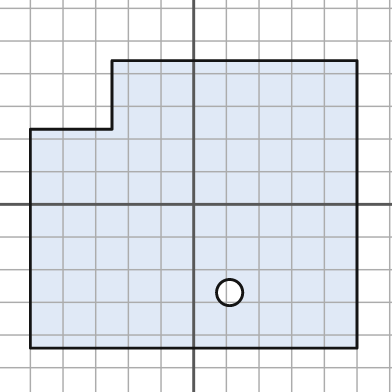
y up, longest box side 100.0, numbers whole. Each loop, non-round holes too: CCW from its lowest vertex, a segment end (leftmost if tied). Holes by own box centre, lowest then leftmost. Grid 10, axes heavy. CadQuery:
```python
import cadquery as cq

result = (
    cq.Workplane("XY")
    .moveTo(-50.0, -44.0)
    .lineTo(50.0, -44.0)
    .lineTo(50.0, 44.0)
    .lineTo(-25.0, 44.0)
    .lineTo(-25.0, 23.0)
    .lineTo(-50.0, 23.0)
    .close()
    .moveTo(11.0, -27.0)
    .circle(4.0)
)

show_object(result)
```